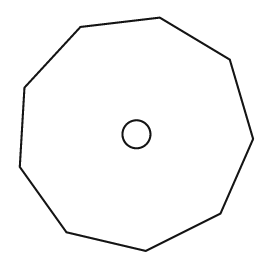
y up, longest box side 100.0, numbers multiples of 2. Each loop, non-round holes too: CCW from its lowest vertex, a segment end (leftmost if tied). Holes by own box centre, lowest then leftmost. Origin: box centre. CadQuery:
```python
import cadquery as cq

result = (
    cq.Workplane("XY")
    .moveTo(4.0, -50.0)
    .lineTo(36.0, -34.0)
    .lineTo(50.0, -2.0)
    .lineTo(40.0, 32.0)
    .lineTo(10.0, 50.0)
    .lineTo(-24.0, 46.0)
    .lineTo(-48.0, 20.0)
    .lineTo(-50.0, -14.0)
    .lineTo(-30.0, -42.0)
    .close()
    .moveTo(0.0, 0.0)
    .circle(6.0)
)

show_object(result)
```